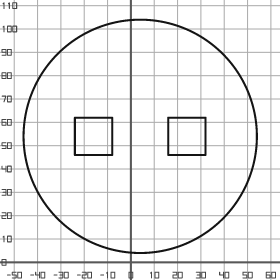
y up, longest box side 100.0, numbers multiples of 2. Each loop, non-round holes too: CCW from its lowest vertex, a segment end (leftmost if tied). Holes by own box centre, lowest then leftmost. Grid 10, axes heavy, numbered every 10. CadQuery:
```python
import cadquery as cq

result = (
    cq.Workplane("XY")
    .moveTo(4.0, 54.0)
    .circle(50.0)
    .moveTo(-24.0, 46.0)
    .lineTo(-8.0, 46.0)
    .lineTo(-8.0, 62.0)
    .lineTo(-24.0, 62.0)
    .close()
    .moveTo(16.0, 46.0)
    .lineTo(32.0, 46.0)
    .lineTo(32.0, 62.0)
    .lineTo(16.0, 62.0)
    .close()
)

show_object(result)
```